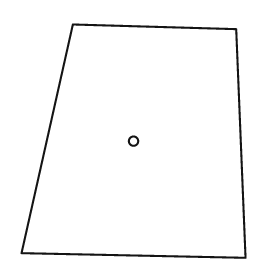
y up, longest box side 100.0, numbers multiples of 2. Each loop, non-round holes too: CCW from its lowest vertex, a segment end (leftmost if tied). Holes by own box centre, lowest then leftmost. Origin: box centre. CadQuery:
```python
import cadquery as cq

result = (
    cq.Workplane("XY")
    .moveTo(48.0, -50.0)
    .lineTo(44.0, 48.0)
    .lineTo(-26.0, 50.0)
    .lineTo(-48.0, -48.0)
    .close()
    .moveTo(0.0, 0.0)
    .circle(2.0)
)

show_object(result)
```